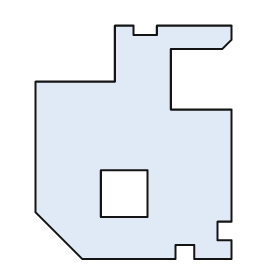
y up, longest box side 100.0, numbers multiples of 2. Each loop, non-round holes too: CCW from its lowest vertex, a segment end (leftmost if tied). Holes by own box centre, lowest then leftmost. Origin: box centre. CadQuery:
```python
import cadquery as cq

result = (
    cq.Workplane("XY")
    .moveTo(-22.0, -50.0)
    .lineTo(18.0, -50.0)
    .lineTo(18.0, -44.0)
    .lineTo(26.0, -44.0)
    .lineTo(26.0, -50.0)
    .lineTo(42.0, -50.0)
    .lineTo(42.0, -42.0)
    .lineTo(36.0, -42.0)
    .lineTo(36.0, -34.0)
    .lineTo(42.0, -34.0)
    .lineTo(42.0, 14.0)
    .lineTo(16.0, 14.0)
    .lineTo(16.0, 40.0)
    .lineTo(38.0, 40.0)
    .lineTo(42.0, 44.0)
    .lineTo(42.0, 50.0)
    .lineTo(10.0, 50.0)
    .lineTo(10.0, 46.0)
    .lineTo(0.0, 46.0)
    .lineTo(0.0, 50.0)
    .lineTo(-8.0, 50.0)
    .lineTo(-8.0, 26.0)
    .lineTo(-42.0, 26.0)
    .lineTo(-42.0, -30.0)
    .close()
    .moveTo(-14.0, -32.0)
    .lineTo(6.0, -32.0)
    .lineTo(6.0, -12.0)
    .lineTo(-14.0, -12.0)
    .close()
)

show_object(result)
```